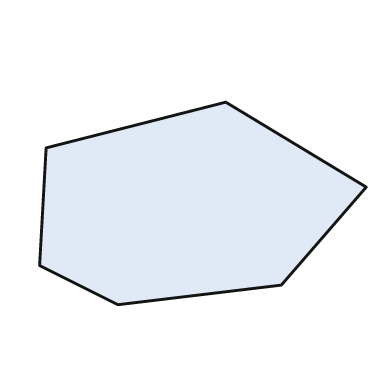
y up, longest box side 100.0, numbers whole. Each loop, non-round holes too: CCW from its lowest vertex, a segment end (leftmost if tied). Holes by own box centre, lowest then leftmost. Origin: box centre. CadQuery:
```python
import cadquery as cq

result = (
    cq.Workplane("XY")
    .moveTo(-26.0, -31.0)
    .lineTo(24.0, -25.0)
    .lineTo(50.0, 5.0)
    .lineTo(7.0, 31.0)
    .lineTo(-48.0, 17.0)
    .lineTo(-50.0, -19.0)
    .close()
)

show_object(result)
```